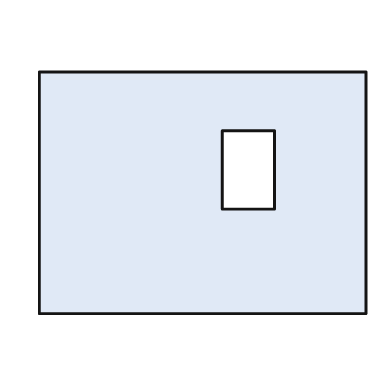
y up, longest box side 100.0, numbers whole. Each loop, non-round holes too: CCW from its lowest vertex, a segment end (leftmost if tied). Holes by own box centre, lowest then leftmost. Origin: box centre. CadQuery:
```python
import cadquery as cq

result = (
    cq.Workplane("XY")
    .moveTo(-50.0, -37.0)
    .lineTo(50.0, -37.0)
    .lineTo(50.0, 37.0)
    .lineTo(-50.0, 37.0)
    .close()
    .moveTo(6.0, -5.0)
    .lineTo(22.0, -5.0)
    .lineTo(22.0, 19.0)
    .lineTo(6.0, 19.0)
    .close()
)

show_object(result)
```